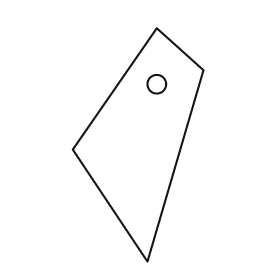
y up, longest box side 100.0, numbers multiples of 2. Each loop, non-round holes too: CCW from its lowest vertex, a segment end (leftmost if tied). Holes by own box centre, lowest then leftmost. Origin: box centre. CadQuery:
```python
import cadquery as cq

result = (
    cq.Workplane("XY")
    .moveTo(4.0, -50.0)
    .lineTo(28.0, 32.0)
    .lineTo(8.0, 50.0)
    .lineTo(-28.0, -2.0)
    .close()
    .moveTo(8.0, 26.0)
    .circle(4.0)
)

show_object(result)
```